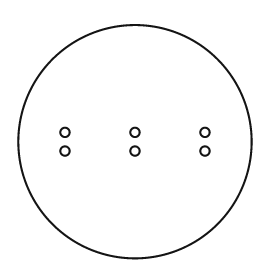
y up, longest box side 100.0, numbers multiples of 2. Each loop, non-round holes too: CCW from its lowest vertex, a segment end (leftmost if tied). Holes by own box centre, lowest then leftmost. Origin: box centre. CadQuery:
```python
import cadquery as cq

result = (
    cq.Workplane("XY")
    .moveTo(0.0, 0.0)
    .circle(50.0)
    .moveTo(-30.0, -4.0)
    .circle(2.0)
    .moveTo(0.0, -4.0)
    .circle(2.0)
    .moveTo(30.0, -4.0)
    .circle(2.0)
    .moveTo(-30.0, 4.0)
    .circle(2.0)
    .moveTo(0.0, 4.0)
    .circle(2.0)
    .moveTo(30.0, 4.0)
    .circle(2.0)
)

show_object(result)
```